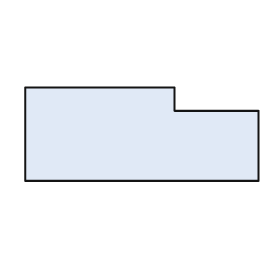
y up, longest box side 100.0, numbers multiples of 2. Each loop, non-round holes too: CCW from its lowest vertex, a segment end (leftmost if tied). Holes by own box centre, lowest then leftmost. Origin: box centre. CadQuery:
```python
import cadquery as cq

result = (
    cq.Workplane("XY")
    .moveTo(-50.0, -20.0)
    .lineTo(50.0, -20.0)
    .lineTo(50.0, 10.0)
    .lineTo(14.0, 10.0)
    .lineTo(14.0, 20.0)
    .lineTo(-50.0, 20.0)
    .close()
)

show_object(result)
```